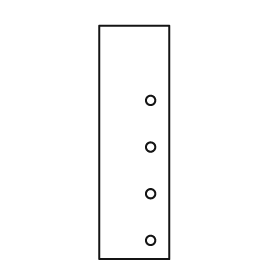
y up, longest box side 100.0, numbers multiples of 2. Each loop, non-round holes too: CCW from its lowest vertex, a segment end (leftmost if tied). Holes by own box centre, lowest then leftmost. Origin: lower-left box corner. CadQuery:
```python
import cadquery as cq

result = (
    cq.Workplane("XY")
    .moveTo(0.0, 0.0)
    .lineTo(30.0, 0.0)
    .lineTo(30.0, 100.0)
    .lineTo(0.0, 100.0)
    .close()
    .moveTo(22.0, 8.0)
    .circle(2.0)
    .moveTo(22.0, 28.0)
    .circle(2.0)
    .moveTo(22.0, 48.0)
    .circle(2.0)
    .moveTo(22.0, 68.0)
    .circle(2.0)
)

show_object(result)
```